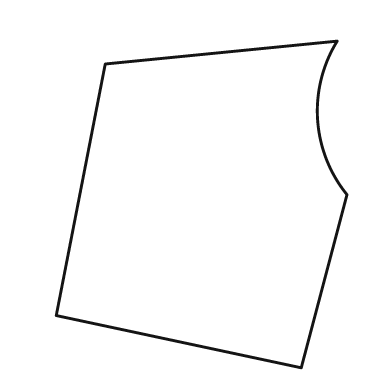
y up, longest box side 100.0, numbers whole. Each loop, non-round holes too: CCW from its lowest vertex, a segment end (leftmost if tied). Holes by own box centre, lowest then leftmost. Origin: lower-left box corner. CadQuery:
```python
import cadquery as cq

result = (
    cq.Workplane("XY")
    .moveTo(75.0, 0.0)
    .lineTo(89.0, 53.0)
    .threePointArc((80.0, 76.0), (86.0, 100.0))
    .lineTo(15.0, 93.0)
    .lineTo(0.0, 16.0)
    .close()
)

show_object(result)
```